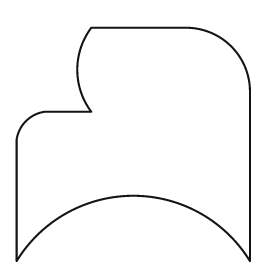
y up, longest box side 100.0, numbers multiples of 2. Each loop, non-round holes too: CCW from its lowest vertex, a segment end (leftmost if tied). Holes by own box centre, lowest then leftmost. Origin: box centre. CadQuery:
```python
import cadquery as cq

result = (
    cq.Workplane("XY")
    .moveTo(-50.0, -50.0)
    .threePointArc((0.0, -22.0), (50.0, -50.0))
    .lineTo(50.0, 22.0)
    .threePointArc((42.0, 42.0), (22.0, 50.0))
    .lineTo(-18.0, 50.0)
    .threePointArc((-24.0, 32.0), (-18.0, 14.0))
    .lineTo(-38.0, 14.0)
    .threePointArc((-46.0, 10.0), (-50.0, 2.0))
    .close()
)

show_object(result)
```